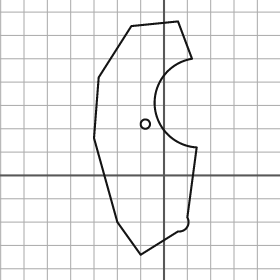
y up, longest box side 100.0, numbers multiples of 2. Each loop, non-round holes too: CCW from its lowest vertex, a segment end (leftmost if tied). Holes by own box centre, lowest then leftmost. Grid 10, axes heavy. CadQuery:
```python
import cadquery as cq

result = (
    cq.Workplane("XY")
    .moveTo(-10.0, -34.0)
    .lineTo(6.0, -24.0)
    .threePointArc((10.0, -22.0), (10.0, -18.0))
    .lineTo(14.0, 12.0)
    .threePointArc((-4.0, 30.0), (12.0, 50.0))
    .lineTo(6.0, 66.0)
    .lineTo(-14.0, 64.0)
    .lineTo(-28.0, 42.0)
    .lineTo(-30.0, 16.0)
    .lineTo(-20.0, -20.0)
    .close()
    .moveTo(-8.0, 22.0)
    .circle(2.0)
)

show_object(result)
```